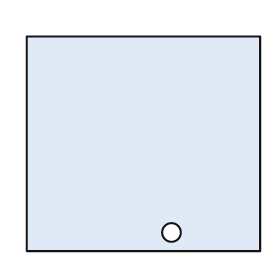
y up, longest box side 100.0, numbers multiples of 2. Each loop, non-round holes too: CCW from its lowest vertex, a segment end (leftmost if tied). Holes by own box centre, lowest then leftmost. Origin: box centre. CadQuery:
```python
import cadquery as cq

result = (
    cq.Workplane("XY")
    .moveTo(-50.0, -46.0)
    .lineTo(50.0, -46.0)
    .lineTo(50.0, 46.0)
    .lineTo(-50.0, 46.0)
    .close()
    .moveTo(12.0, -38.0)
    .circle(4.0)
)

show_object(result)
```